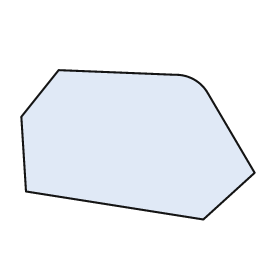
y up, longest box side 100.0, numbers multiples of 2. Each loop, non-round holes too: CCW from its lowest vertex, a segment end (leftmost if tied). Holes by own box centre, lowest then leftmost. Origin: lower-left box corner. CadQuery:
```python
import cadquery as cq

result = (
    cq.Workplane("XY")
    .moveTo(78.0, 0.0)
    .lineTo(100.0, 20.0)
    .lineTo(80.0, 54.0)
    .threePointArc((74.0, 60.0), (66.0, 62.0))
    .lineTo(16.0, 64.0)
    .lineTo(0.0, 44.0)
    .lineTo(2.0, 12.0)
    .close()
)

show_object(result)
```